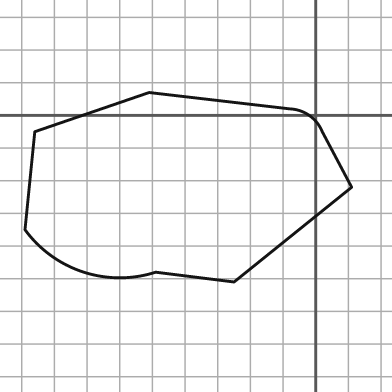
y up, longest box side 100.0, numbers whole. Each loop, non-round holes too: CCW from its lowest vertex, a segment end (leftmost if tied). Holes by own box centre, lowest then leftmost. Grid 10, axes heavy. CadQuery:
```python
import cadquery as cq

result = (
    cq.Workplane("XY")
    .moveTo(-25.0, -51.0)
    .lineTo(11.0, -22.0)
    .lineTo(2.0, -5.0)
    .threePointArc((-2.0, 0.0), (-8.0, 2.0))
    .lineTo(-51.0, 7.0)
    .lineTo(-86.0, -5.0)
    .lineTo(-89.0, -35.0)
    .threePointArc((-71.0, -48.0), (-49.0, -48.0))
    .close()
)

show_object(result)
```